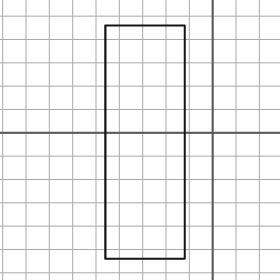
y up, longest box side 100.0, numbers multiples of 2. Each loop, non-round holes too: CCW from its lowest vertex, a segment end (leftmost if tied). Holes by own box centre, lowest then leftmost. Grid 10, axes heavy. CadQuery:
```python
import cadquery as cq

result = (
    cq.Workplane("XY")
    .moveTo(-46.0, -54.0)
    .lineTo(-12.0, -54.0)
    .lineTo(-12.0, 46.0)
    .lineTo(-46.0, 46.0)
    .close()
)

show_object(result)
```